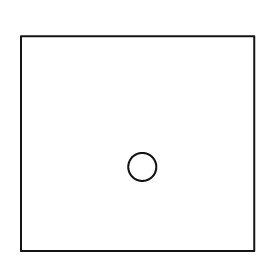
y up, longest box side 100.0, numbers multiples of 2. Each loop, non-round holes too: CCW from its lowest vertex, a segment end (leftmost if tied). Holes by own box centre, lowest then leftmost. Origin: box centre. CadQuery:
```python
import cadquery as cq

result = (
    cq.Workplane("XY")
    .moveTo(-50.0, -46.0)
    .lineTo(50.0, -46.0)
    .lineTo(50.0, 46.0)
    .lineTo(-50.0, 46.0)
    .close()
    .moveTo(2.0, -10.0)
    .circle(6.0)
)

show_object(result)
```